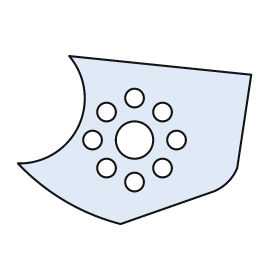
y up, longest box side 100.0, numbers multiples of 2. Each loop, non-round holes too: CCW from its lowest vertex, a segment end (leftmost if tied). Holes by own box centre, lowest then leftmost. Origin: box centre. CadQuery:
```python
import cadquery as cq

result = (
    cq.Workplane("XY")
    .moveTo(-6.0, -36.0)
    .lineTo(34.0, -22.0)
    .threePointArc((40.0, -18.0), (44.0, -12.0))
    .lineTo(50.0, 28.0)
    .lineTo(-28.0, 36.0)
    .threePointArc((-24.0, 6.0), (-50.0, -10.0))
    .threePointArc((-30.0, -26.0), (-6.0, -36.0))
    .close()
    .moveTo(0.0, -18.0)
    .circle(4.0)
    .moveTo(-12.0, -12.0)
    .circle(4.0)
    .moveTo(12.0, -12.0)
    .circle(4.0)
    .moveTo(-18.0, 0.0)
    .circle(4.0)
    .moveTo(0.0, 0.0)
    .circle(8.0)
    .moveTo(18.0, 0.0)
    .circle(4.0)
    .moveTo(-12.0, 12.0)
    .circle(4.0)
    .moveTo(12.0, 12.0)
    .circle(4.0)
    .moveTo(0.0, 18.0)
    .circle(4.0)
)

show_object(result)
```